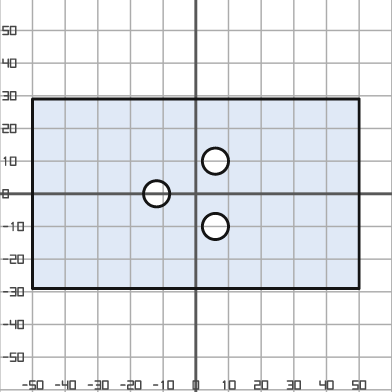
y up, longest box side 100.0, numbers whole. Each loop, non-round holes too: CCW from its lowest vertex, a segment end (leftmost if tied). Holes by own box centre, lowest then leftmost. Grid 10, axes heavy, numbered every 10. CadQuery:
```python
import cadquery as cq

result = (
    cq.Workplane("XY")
    .moveTo(-50.0, -29.0)
    .lineTo(50.0, -29.0)
    .lineTo(50.0, 29.0)
    .lineTo(-50.0, 29.0)
    .close()
    .moveTo(6.0, -10.0)
    .circle(4.0)
    .moveTo(-12.0, 0.0)
    .circle(4.0)
    .moveTo(6.0, 10.0)
    .circle(4.0)
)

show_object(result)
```